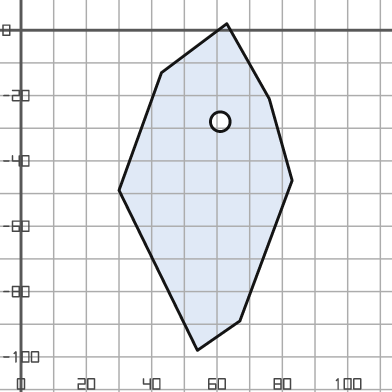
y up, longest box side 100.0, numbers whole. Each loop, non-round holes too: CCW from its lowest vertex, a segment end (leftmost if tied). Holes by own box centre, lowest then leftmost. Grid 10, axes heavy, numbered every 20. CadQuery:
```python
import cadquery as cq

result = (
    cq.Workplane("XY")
    .moveTo(54.0, -98.0)
    .lineTo(67.0, -89.0)
    .lineTo(83.0, -46.0)
    .lineTo(76.0, -21.0)
    .lineTo(63.0, 2.0)
    .lineTo(43.0, -13.0)
    .lineTo(30.0, -49.0)
    .close()
    .moveTo(61.0, -28.0)
    .circle(3.0)
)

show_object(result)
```